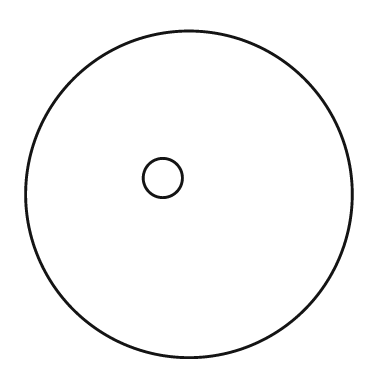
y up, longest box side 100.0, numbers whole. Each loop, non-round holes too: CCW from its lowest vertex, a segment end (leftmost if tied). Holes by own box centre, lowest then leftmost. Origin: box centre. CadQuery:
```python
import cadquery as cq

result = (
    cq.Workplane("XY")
    .moveTo(0.0, 0.0)
    .circle(50.0)
    .moveTo(-8.0, 5.0)
    .circle(6.0)
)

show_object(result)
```